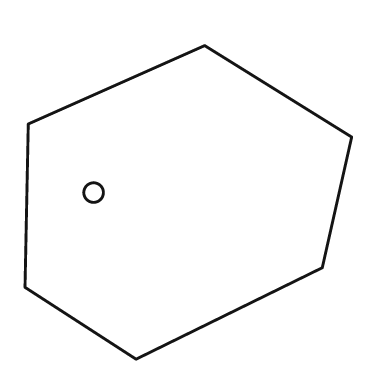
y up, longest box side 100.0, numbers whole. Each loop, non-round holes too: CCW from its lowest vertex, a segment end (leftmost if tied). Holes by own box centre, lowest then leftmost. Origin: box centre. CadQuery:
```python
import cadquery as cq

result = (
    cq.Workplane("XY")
    .moveTo(-16.0, -48.0)
    .lineTo(41.0, -20.0)
    .lineTo(50.0, 20.0)
    .lineTo(5.0, 48.0)
    .lineTo(-49.0, 24.0)
    .lineTo(-50.0, -26.0)
    .close()
    .moveTo(-29.0, 3.0)
    .circle(3.0)
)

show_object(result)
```